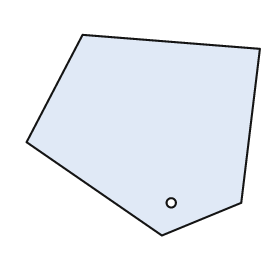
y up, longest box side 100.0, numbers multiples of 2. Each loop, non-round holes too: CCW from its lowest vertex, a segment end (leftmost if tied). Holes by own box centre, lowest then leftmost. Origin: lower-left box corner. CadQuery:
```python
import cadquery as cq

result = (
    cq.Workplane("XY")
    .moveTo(58.0, 0.0)
    .lineTo(92.0, 14.0)
    .lineTo(100.0, 80.0)
    .lineTo(24.0, 86.0)
    .lineTo(0.0, 40.0)
    .close()
    .moveTo(62.0, 14.0)
    .circle(2.0)
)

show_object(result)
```